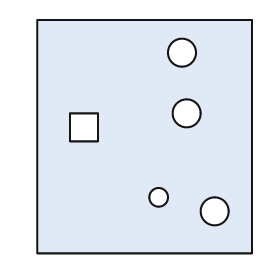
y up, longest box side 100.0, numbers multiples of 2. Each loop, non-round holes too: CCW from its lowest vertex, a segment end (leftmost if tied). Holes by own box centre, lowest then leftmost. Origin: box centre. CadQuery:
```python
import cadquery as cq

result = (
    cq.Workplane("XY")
    .moveTo(-46.0, -50.0)
    .lineTo(46.0, -50.0)
    .lineTo(46.0, 50.0)
    .lineTo(-46.0, 50.0)
    .close()
    .moveTo(30.0, -32.0)
    .circle(6.0)
    .moveTo(6.0, -26.0)
    .circle(4.0)
    .moveTo(-32.0, -2.0)
    .lineTo(-20.0, -2.0)
    .lineTo(-20.0, 10.0)
    .lineTo(-32.0, 10.0)
    .close()
    .moveTo(18.0, 10.0)
    .circle(6.0)
    .moveTo(16.0, 36.0)
    .circle(6.0)
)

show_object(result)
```